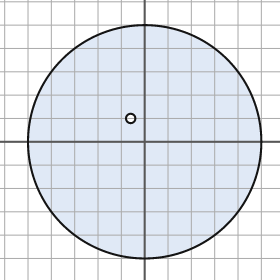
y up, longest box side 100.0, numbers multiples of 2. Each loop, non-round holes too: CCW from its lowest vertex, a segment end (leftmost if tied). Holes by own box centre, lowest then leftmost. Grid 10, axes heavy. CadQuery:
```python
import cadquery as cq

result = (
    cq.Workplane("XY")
    .moveTo(0.0, 0.0)
    .circle(50.0)
    .moveTo(-6.0, 10.0)
    .circle(2.0)
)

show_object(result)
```